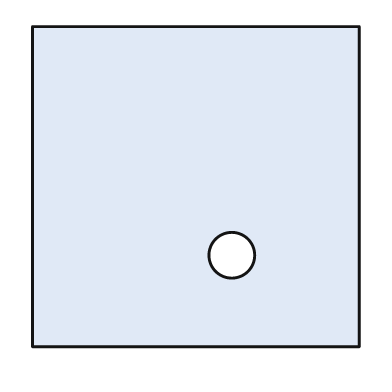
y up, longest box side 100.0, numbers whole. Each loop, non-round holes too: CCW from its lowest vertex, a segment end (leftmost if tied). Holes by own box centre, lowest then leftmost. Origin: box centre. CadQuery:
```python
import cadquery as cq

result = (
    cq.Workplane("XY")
    .moveTo(-50.0, -49.0)
    .lineTo(50.0, -49.0)
    .lineTo(50.0, 49.0)
    .lineTo(-50.0, 49.0)
    .close()
    .moveTo(11.0, -21.0)
    .circle(7.0)
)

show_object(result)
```